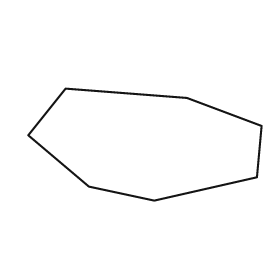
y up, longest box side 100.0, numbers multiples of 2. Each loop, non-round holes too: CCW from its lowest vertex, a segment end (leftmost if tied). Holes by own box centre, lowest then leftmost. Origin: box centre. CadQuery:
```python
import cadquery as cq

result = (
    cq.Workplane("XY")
    .moveTo(4.0, -24.0)
    .lineTo(48.0, -14.0)
    .lineTo(50.0, 8.0)
    .lineTo(18.0, 20.0)
    .lineTo(-34.0, 24.0)
    .lineTo(-50.0, 4.0)
    .lineTo(-24.0, -18.0)
    .close()
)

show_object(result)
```